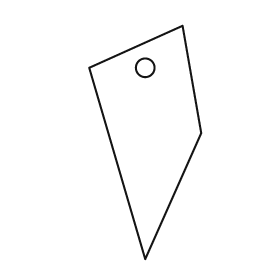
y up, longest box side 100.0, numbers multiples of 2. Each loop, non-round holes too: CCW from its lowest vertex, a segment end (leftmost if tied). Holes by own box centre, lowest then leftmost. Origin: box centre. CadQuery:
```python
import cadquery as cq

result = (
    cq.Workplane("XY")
    .moveTo(0.0, -50.0)
    .lineTo(24.0, 4.0)
    .lineTo(16.0, 50.0)
    .lineTo(-24.0, 32.0)
    .close()
    .moveTo(0.0, 32.0)
    .circle(4.0)
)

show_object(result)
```